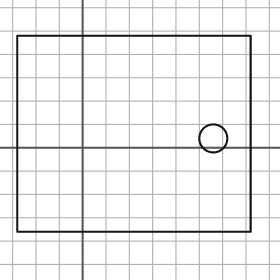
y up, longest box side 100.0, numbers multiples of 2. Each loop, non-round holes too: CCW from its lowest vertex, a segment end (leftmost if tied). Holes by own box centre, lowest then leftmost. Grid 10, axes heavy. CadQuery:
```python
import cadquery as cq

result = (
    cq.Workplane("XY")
    .moveTo(-28.0, -36.0)
    .lineTo(72.0, -36.0)
    .lineTo(72.0, 48.0)
    .lineTo(-28.0, 48.0)
    .close()
    .moveTo(56.0, 4.0)
    .circle(6.0)
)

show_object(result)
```